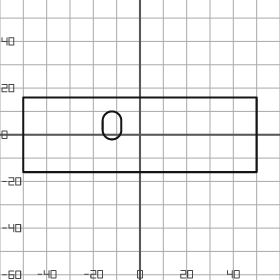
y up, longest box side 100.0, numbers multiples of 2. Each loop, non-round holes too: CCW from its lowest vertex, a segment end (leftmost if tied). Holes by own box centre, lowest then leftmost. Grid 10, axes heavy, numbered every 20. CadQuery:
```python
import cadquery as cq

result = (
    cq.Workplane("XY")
    .moveTo(-50.0, -16.0)
    .lineTo(50.0, -16.0)
    .lineTo(50.0, 16.0)
    .lineTo(-50.0, 16.0)
    .close()
    .moveTo(-16.0, 2.0)
    .threePointArc((-12.0, -2.0), (-8.0, 2.0))
    .lineTo(-8.0, 6.0)
    .threePointArc((-12.0, 10.0), (-16.0, 6.0))
    .close()
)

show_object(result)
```